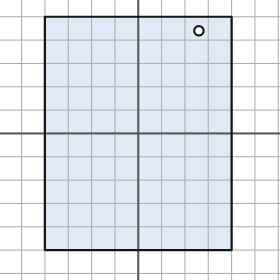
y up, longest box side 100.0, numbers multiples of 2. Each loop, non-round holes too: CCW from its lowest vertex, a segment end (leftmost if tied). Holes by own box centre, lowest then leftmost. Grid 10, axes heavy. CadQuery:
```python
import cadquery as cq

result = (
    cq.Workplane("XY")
    .moveTo(-40.0, -50.0)
    .lineTo(40.0, -50.0)
    .lineTo(40.0, 50.0)
    .lineTo(-40.0, 50.0)
    .close()
    .moveTo(26.0, 44.0)
    .circle(2.0)
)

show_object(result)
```